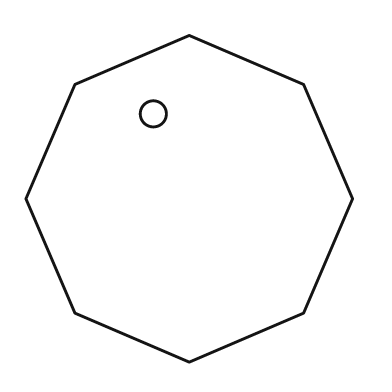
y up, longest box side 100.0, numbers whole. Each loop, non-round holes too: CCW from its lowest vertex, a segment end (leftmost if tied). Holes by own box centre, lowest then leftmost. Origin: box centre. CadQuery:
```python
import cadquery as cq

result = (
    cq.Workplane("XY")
    .moveTo(0.0, -50.0)
    .lineTo(35.0, -35.0)
    .lineTo(50.0, 0.0)
    .lineTo(35.0, 35.0)
    .lineTo(0.0, 50.0)
    .lineTo(-35.0, 35.0)
    .lineTo(-50.0, 0.0)
    .lineTo(-35.0, -35.0)
    .close()
    .moveTo(-11.0, 26.0)
    .circle(4.0)
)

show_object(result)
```